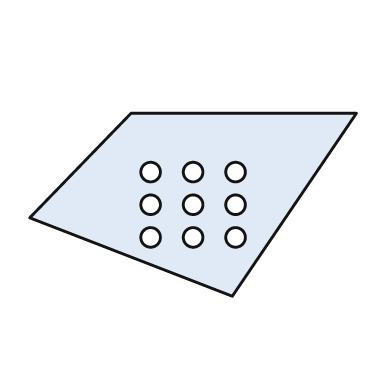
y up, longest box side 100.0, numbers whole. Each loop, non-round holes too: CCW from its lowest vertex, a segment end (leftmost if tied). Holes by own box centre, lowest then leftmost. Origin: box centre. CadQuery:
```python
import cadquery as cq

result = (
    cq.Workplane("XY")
    .moveTo(12.0, -28.0)
    .lineTo(50.0, 28.0)
    .lineTo(-19.0, 28.0)
    .lineTo(-50.0, -4.0)
    .close()
    .moveTo(-13.0, -10.0)
    .circle(3.0)
    .moveTo(0.0, -10.0)
    .circle(3.0)
    .moveTo(13.0, -10.0)
    .circle(3.0)
    .moveTo(-13.0, 0.0)
    .circle(3.0)
    .moveTo(0.0, 0.0)
    .circle(3.0)
    .moveTo(13.0, 0.0)
    .circle(3.0)
    .moveTo(-13.0, 10.0)
    .circle(3.0)
    .moveTo(0.0, 10.0)
    .circle(3.0)
    .moveTo(13.0, 10.0)
    .circle(3.0)
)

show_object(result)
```